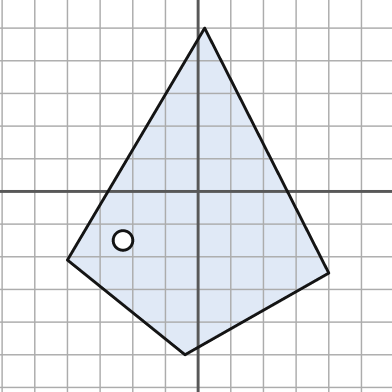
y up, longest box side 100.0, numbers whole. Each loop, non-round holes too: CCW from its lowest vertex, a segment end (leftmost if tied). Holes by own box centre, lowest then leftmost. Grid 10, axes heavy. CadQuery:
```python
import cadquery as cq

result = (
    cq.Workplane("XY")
    .moveTo(-4.0, -50.0)
    .lineTo(40.0, -25.0)
    .lineTo(2.0, 50.0)
    .lineTo(-40.0, -21.0)
    .close()
    .moveTo(-23.0, -15.0)
    .circle(3.0)
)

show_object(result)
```